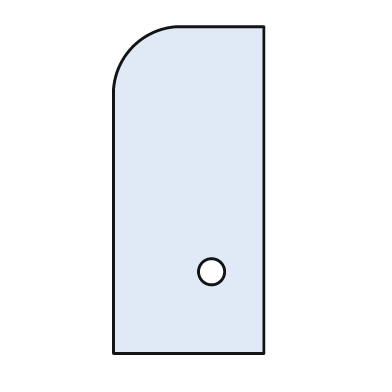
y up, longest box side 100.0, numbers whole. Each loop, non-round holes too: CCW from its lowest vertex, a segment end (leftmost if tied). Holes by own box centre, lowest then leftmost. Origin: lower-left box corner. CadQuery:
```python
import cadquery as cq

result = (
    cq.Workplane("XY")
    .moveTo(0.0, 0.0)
    .lineTo(46.0, 0.0)
    .lineTo(46.0, 100.0)
    .lineTo(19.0, 100.0)
    .threePointArc((6.0, 94.0), (0.0, 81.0))
    .close()
    .moveTo(30.0, 25.0)
    .circle(4.0)
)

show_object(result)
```